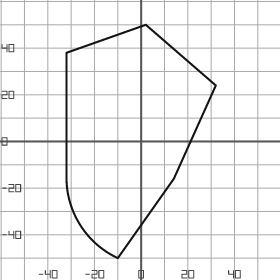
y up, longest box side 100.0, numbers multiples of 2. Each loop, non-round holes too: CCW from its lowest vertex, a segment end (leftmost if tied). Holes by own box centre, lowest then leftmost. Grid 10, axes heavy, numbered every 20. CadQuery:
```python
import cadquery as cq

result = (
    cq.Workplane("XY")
    .moveTo(-10.0, -50.0)
    .lineTo(14.0, -16.0)
    .lineTo(32.0, 24.0)
    .lineTo(2.0, 50.0)
    .lineTo(-32.0, 38.0)
    .lineTo(-32.0, -16.0)
    .threePointArc((-26.0, -36.0), (-10.0, -50.0))
    .close()
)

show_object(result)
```